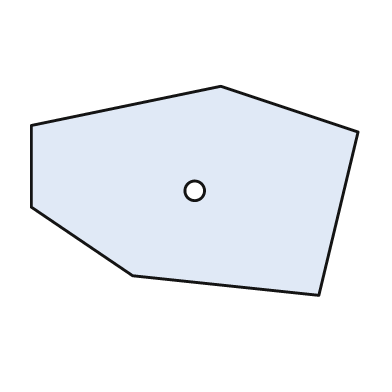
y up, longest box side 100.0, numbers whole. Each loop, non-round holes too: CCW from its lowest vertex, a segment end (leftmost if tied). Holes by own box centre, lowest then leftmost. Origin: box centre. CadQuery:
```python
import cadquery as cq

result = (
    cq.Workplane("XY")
    .moveTo(38.0, -32.0)
    .lineTo(50.0, 18.0)
    .lineTo(8.0, 32.0)
    .lineTo(-50.0, 20.0)
    .lineTo(-50.0, -5.0)
    .lineTo(-19.0, -26.0)
    .close()
    .moveTo(0.0, 0.0)
    .circle(3.0)
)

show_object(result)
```